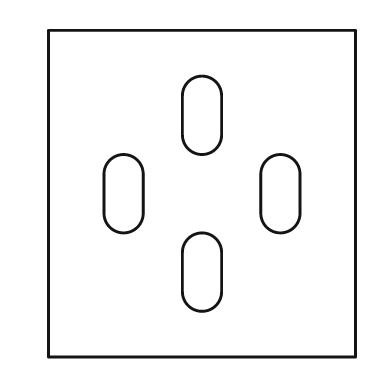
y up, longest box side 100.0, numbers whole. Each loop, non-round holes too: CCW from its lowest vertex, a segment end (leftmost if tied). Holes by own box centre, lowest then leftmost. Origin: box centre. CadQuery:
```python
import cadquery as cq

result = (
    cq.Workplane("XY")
    .moveTo(-47.0, -50.0)
    .lineTo(47.0, -50.0)
    .lineTo(47.0, 50.0)
    .lineTo(-47.0, 50.0)
    .close()
    .moveTo(-6.0, -30.0)
    .threePointArc((0.0, -36.0), (6.0, -30.0))
    .lineTo(6.0, -18.0)
    .threePointArc((0.0, -12.0), (-6.0, -18.0))
    .close()
    .moveTo(-30.0, -6.0)
    .threePointArc((-24.0, -12.0), (-18.0, -6.0))
    .lineTo(-18.0, 6.0)
    .threePointArc((-24.0, 12.0), (-30.0, 6.0))
    .close()
    .moveTo(18.0, -6.0)
    .threePointArc((24.0, -12.0), (30.0, -6.0))
    .lineTo(30.0, 6.0)
    .threePointArc((24.0, 12.0), (18.0, 6.0))
    .close()
    .moveTo(-6.0, 18.0)
    .threePointArc((0.0, 12.0), (6.0, 18.0))
    .lineTo(6.0, 30.0)
    .threePointArc((0.0, 36.0), (-6.0, 30.0))
    .close()
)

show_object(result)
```